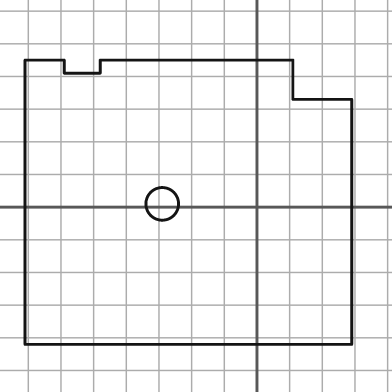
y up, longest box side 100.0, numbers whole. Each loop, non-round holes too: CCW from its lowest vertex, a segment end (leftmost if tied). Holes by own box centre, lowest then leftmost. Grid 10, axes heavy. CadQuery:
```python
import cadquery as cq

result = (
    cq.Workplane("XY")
    .moveTo(-71.0, -42.0)
    .lineTo(29.0, -42.0)
    .lineTo(29.0, 33.0)
    .lineTo(11.0, 33.0)
    .lineTo(11.0, 45.0)
    .lineTo(-48.0, 45.0)
    .lineTo(-48.0, 41.0)
    .lineTo(-59.0, 41.0)
    .lineTo(-59.0, 45.0)
    .lineTo(-71.0, 45.0)
    .close()
    .moveTo(-29.0, 1.0)
    .circle(5.0)
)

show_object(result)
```